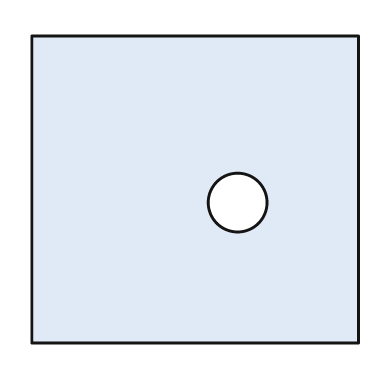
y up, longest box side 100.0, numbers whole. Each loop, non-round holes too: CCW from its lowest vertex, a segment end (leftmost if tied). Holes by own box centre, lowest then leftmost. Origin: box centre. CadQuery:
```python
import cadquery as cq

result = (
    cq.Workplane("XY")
    .moveTo(-50.0, -47.0)
    .lineTo(50.0, -47.0)
    .lineTo(50.0, 47.0)
    .lineTo(-50.0, 47.0)
    .close()
    .moveTo(13.0, -4.0)
    .circle(9.0)
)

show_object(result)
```